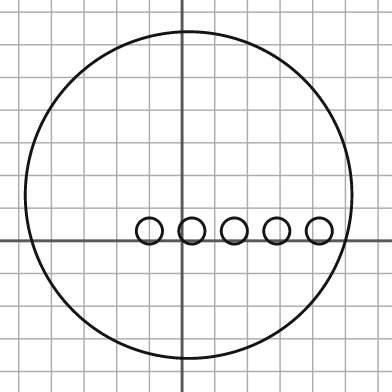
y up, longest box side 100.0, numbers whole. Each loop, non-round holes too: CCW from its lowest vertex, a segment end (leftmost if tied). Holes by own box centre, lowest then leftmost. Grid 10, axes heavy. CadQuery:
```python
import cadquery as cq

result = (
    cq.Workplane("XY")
    .moveTo(2.0, 14.0)
    .circle(50.0)
    .moveTo(-10.0, 3.0)
    .circle(4.0)
    .moveTo(3.0, 3.0)
    .circle(4.0)
    .moveTo(16.0, 3.0)
    .circle(4.0)
    .moveTo(29.0, 3.0)
    .circle(4.0)
    .moveTo(42.0, 3.0)
    .circle(4.0)
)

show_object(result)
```